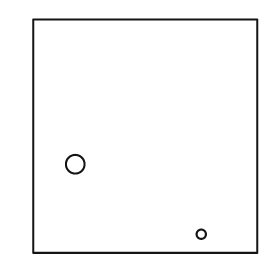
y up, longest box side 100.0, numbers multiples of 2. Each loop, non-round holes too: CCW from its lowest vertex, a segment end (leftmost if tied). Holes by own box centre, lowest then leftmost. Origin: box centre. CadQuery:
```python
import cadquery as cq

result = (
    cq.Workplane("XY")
    .moveTo(-48.0, -50.0)
    .lineTo(48.0, -50.0)
    .lineTo(48.0, 50.0)
    .lineTo(-48.0, 50.0)
    .close()
    .moveTo(24.0, -42.0)
    .circle(2.0)
    .moveTo(-30.0, -12.0)
    .circle(4.0)
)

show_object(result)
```